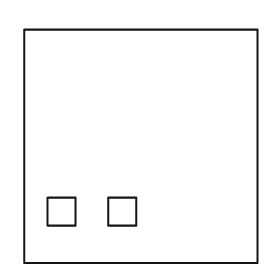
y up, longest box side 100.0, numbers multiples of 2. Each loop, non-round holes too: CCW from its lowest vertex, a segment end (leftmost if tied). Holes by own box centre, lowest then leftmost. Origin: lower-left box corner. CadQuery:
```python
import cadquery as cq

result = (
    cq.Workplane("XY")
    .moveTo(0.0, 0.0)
    .lineTo(100.0, 0.0)
    .lineTo(100.0, 100.0)
    .lineTo(0.0, 100.0)
    .close()
    .moveTo(10.0, 16.0)
    .lineTo(22.0, 16.0)
    .lineTo(22.0, 28.0)
    .lineTo(10.0, 28.0)
    .close()
    .moveTo(36.0, 16.0)
    .lineTo(48.0, 16.0)
    .lineTo(48.0, 28.0)
    .lineTo(36.0, 28.0)
    .close()
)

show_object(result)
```